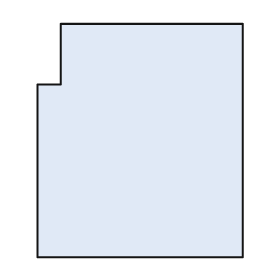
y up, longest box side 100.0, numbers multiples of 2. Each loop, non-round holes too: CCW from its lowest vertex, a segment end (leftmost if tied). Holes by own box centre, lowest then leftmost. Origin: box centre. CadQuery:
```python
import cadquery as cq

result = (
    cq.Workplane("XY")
    .moveTo(-44.0, -50.0)
    .lineTo(44.0, -50.0)
    .lineTo(44.0, 50.0)
    .lineTo(-34.0, 50.0)
    .lineTo(-34.0, 24.0)
    .lineTo(-44.0, 24.0)
    .close()
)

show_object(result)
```